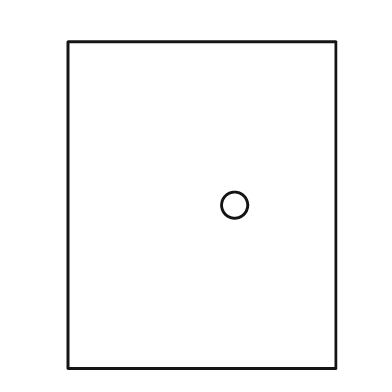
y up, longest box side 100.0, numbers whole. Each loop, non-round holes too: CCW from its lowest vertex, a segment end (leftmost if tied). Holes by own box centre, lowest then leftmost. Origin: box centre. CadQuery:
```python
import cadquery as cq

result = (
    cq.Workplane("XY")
    .moveTo(-41.0, -50.0)
    .lineTo(41.0, -50.0)
    .lineTo(41.0, 50.0)
    .lineTo(-41.0, 50.0)
    .close()
    .moveTo(10.0, 0.0)
    .circle(4.0)
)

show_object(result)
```